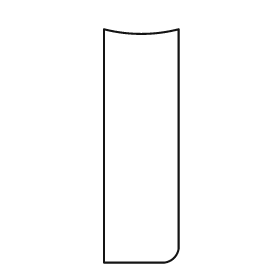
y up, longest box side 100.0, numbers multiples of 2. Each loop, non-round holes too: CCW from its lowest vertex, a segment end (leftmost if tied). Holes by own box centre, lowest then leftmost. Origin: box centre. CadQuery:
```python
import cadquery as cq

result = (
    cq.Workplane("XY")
    .moveTo(-16.0, -50.0)
    .lineTo(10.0, -50.0)
    .threePointArc((14.0, -48.0), (16.0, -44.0))
    .lineTo(16.0, 50.0)
    .threePointArc((0.0, 48.0), (-16.0, 50.0))
    .close()
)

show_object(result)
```